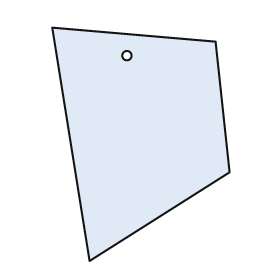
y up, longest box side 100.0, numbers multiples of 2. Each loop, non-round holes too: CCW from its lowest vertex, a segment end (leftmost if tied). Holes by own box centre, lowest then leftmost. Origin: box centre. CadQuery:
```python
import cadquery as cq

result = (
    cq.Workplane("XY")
    .moveTo(-22.0, -50.0)
    .lineTo(38.0, -12.0)
    .lineTo(32.0, 44.0)
    .lineTo(-38.0, 50.0)
    .close()
    .moveTo(-6.0, 38.0)
    .circle(2.0)
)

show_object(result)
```